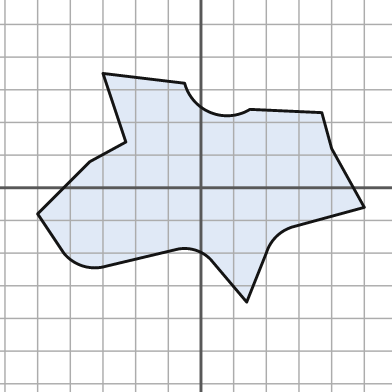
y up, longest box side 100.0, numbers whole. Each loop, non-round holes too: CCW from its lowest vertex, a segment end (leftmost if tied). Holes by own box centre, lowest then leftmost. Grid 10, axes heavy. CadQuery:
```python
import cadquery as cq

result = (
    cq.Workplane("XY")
    .moveTo(14.0, -35.0)
    .lineTo(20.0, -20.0)
    .threePointArc((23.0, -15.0), (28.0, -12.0))
    .lineTo(50.0, -6.0)
    .lineTo(40.0, 12.0)
    .lineTo(37.0, 23.0)
    .lineTo(15.0, 24.0)
    .threePointArc((3.0, 23.0), (-5.0, 32.0))
    .lineTo(-30.0, 35.0)
    .lineTo(-23.0, 14.0)
    .lineTo(-34.0, 8.0)
    .lineTo(-50.0, -8.0)
    .lineTo(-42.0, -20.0)
    .threePointArc((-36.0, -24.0), (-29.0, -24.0))
    .lineTo(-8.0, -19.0)
    .threePointArc((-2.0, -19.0), (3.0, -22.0))
    .close()
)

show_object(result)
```